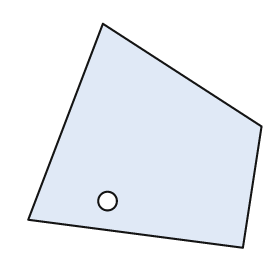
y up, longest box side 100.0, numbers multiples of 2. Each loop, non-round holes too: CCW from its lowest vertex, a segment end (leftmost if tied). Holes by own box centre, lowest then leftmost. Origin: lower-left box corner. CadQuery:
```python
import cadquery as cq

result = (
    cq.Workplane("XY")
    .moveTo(92.0, 0.0)
    .lineTo(100.0, 52.0)
    .lineTo(32.0, 96.0)
    .lineTo(0.0, 12.0)
    .close()
    .moveTo(34.0, 20.0)
    .circle(4.0)
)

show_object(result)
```